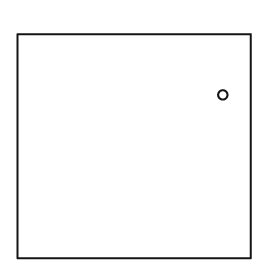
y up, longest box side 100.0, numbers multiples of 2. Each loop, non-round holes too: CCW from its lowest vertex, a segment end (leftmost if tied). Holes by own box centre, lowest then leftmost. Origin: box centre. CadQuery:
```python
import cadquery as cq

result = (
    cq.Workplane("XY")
    .moveTo(-50.0, -48.0)
    .lineTo(50.0, -48.0)
    .lineTo(50.0, 48.0)
    .lineTo(-50.0, 48.0)
    .close()
    .moveTo(38.0, 22.0)
    .circle(2.0)
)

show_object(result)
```